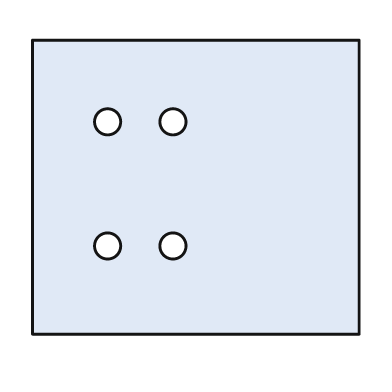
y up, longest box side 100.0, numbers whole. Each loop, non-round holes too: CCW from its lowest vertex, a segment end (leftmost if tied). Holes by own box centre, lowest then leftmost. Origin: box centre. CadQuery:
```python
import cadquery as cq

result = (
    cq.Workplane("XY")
    .moveTo(-50.0, -45.0)
    .lineTo(50.0, -45.0)
    .lineTo(50.0, 45.0)
    .lineTo(-50.0, 45.0)
    .close()
    .moveTo(-27.0, -18.0)
    .circle(4.0)
    .moveTo(-7.0, -18.0)
    .circle(4.0)
    .moveTo(-27.0, 20.0)
    .circle(4.0)
    .moveTo(-7.0, 20.0)
    .circle(4.0)
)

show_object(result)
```